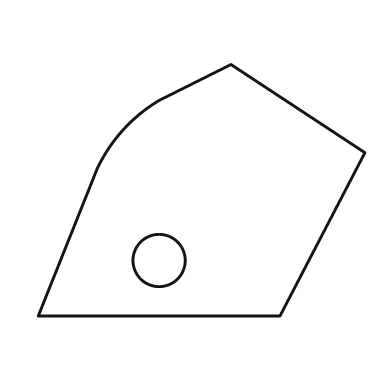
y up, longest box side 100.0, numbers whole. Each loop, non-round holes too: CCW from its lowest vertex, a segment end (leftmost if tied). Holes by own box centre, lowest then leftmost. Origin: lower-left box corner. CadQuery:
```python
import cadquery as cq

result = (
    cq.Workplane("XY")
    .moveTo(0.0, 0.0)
    .lineTo(74.0, 0.0)
    .lineTo(100.0, 50.0)
    .lineTo(59.0, 77.0)
    .lineTo(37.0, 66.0)
    .threePointArc((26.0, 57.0), (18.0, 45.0))
    .close()
    .moveTo(37.0, 17.0)
    .circle(8.0)
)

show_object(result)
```